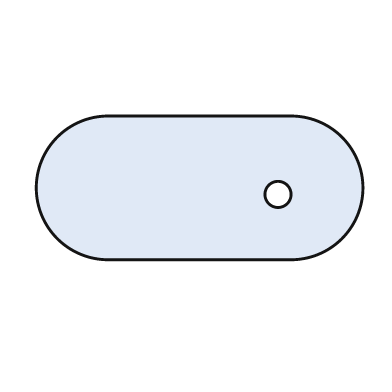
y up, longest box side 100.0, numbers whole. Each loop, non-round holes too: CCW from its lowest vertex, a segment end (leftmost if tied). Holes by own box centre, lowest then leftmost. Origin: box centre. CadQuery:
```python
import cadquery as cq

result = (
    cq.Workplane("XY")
    .moveTo(-28.0, -22.0)
    .lineTo(28.0, -22.0)
    .threePointArc((50.0, 0.0), (28.0, 22.0))
    .lineTo(-28.0, 22.0)
    .threePointArc((-50.0, 0.0), (-28.0, -22.0))
    .close()
    .moveTo(24.0, -2.0)
    .circle(4.0)
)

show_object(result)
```